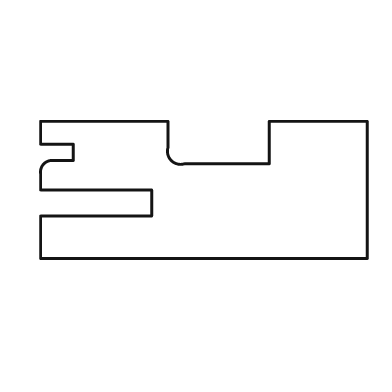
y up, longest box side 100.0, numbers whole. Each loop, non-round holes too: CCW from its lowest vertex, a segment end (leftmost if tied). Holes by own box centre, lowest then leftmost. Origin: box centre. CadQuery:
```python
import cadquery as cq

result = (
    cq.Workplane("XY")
    .moveTo(-50.0, -21.0)
    .lineTo(50.0, -21.0)
    .lineTo(50.0, 21.0)
    .lineTo(20.0, 21.0)
    .lineTo(20.0, 8.0)
    .lineTo(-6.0, 8.0)
    .threePointArc((-10.0, 9.0), (-11.0, 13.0))
    .lineTo(-11.0, 21.0)
    .lineTo(-50.0, 21.0)
    .lineTo(-50.0, 14.0)
    .lineTo(-40.0, 14.0)
    .lineTo(-40.0, 9.0)
    .lineTo(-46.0, 9.0)
    .threePointArc((-49.0, 8.0), (-50.0, 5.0))
    .lineTo(-50.0, 0.0)
    .lineTo(-16.0, 0.0)
    .lineTo(-16.0, -8.0)
    .lineTo(-50.0, -8.0)
    .close()
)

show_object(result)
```